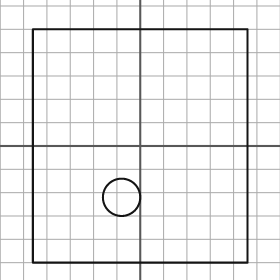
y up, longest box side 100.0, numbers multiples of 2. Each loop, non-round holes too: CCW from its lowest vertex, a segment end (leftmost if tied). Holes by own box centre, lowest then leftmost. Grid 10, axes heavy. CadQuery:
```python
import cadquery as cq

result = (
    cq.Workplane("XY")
    .moveTo(-46.0, -50.0)
    .lineTo(46.0, -50.0)
    .lineTo(46.0, 50.0)
    .lineTo(-46.0, 50.0)
    .close()
    .moveTo(-8.0, -22.0)
    .circle(8.0)
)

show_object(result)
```